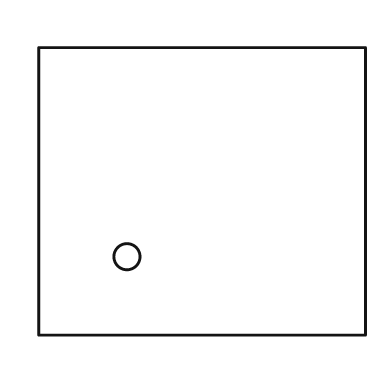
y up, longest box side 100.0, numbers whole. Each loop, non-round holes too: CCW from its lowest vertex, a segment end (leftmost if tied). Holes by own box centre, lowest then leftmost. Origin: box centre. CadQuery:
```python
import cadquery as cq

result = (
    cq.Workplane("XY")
    .moveTo(-50.0, -44.0)
    .lineTo(50.0, -44.0)
    .lineTo(50.0, 44.0)
    .lineTo(-50.0, 44.0)
    .close()
    .moveTo(-23.0, -20.0)
    .circle(4.0)
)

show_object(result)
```